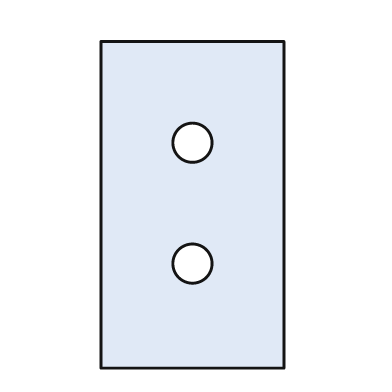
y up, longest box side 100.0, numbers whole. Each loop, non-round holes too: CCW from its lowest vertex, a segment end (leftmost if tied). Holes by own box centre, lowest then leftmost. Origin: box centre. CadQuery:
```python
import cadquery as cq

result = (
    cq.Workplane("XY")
    .moveTo(-28.0, -50.0)
    .lineTo(28.0, -50.0)
    .lineTo(28.0, 50.0)
    .lineTo(-28.0, 50.0)
    .close()
    .moveTo(0.0, -18.0)
    .circle(6.0)
    .moveTo(0.0, 19.0)
    .circle(6.0)
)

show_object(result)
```